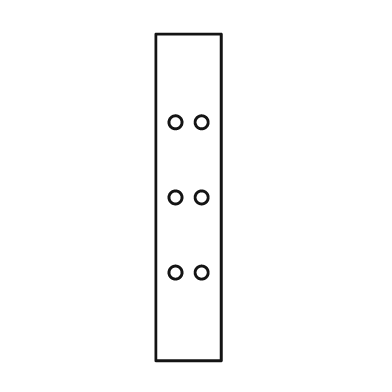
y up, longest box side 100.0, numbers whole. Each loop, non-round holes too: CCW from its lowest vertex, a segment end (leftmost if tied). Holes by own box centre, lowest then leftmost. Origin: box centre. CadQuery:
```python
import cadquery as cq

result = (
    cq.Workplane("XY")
    .moveTo(-10.0, -50.0)
    .lineTo(10.0, -50.0)
    .lineTo(10.0, 50.0)
    .lineTo(-10.0, 50.0)
    .close()
    .moveTo(-4.0, -23.0)
    .circle(2.0)
    .moveTo(4.0, -23.0)
    .circle(2.0)
    .moveTo(-4.0, 0.0)
    .circle(2.0)
    .moveTo(4.0, 0.0)
    .circle(2.0)
    .moveTo(-4.0, 23.0)
    .circle(2.0)
    .moveTo(4.0, 23.0)
    .circle(2.0)
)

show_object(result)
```